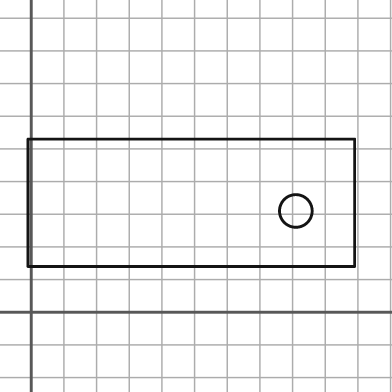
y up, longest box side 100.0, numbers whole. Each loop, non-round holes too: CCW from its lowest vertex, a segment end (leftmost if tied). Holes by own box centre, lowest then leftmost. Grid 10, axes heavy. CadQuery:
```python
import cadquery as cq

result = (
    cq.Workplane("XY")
    .moveTo(-1.0, 14.0)
    .lineTo(99.0, 14.0)
    .lineTo(99.0, 53.0)
    .lineTo(-1.0, 53.0)
    .close()
    .moveTo(81.0, 31.0)
    .circle(5.0)
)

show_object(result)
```